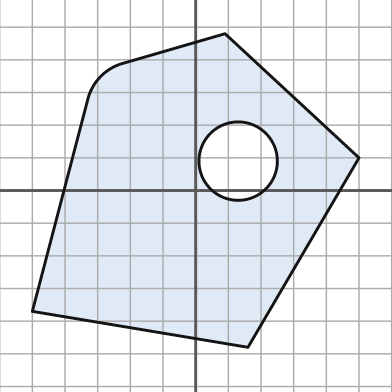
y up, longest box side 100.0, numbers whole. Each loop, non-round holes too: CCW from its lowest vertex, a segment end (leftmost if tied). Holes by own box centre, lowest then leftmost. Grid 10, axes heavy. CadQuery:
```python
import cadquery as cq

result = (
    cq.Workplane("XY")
    .moveTo(16.0, -48.0)
    .lineTo(50.0, 10.0)
    .lineTo(9.0, 48.0)
    .lineTo(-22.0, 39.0)
    .threePointArc((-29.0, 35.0), (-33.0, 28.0))
    .lineTo(-50.0, -37.0)
    .close()
    .moveTo(13.0, 9.0)
    .circle(12.0)
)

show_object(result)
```